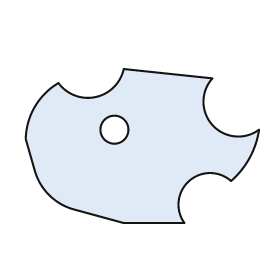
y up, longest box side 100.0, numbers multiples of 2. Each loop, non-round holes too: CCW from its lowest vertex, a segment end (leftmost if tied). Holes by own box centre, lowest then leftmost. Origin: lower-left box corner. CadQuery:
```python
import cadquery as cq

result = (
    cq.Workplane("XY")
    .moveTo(42.0, 0.0)
    .lineTo(68.0, 0.0)
    .threePointArc((70.0, 18.0), (88.0, 18.0))
    .threePointArc((96.0, 28.0), (100.0, 40.0))
    .threePointArc((80.0, 42.0), (80.0, 62.0))
    .lineTo(42.0, 66.0)
    .threePointArc((30.0, 54.0), (14.0, 60.0))
    .threePointArc((4.0, 50.0), (0.0, 36.0))
    .lineTo(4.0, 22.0)
    .threePointArc((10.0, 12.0), (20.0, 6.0))
    .close()
    .moveTo(38.0, 40.0)
    .circle(6.0)
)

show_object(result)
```